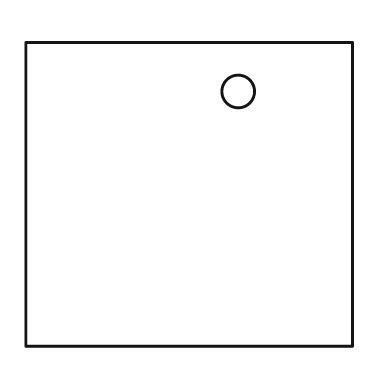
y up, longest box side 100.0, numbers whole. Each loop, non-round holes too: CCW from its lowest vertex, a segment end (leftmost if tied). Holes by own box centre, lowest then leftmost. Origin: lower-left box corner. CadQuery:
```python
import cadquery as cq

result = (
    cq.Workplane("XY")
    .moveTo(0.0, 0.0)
    .lineTo(100.0, 0.0)
    .lineTo(100.0, 93.0)
    .lineTo(0.0, 93.0)
    .close()
    .moveTo(65.0, 78.0)
    .circle(5.0)
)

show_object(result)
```